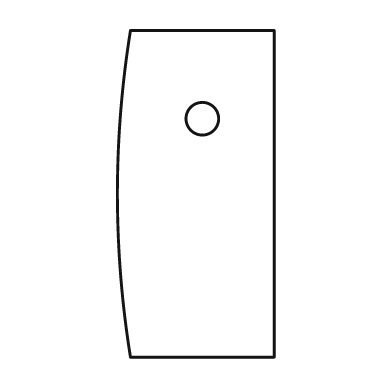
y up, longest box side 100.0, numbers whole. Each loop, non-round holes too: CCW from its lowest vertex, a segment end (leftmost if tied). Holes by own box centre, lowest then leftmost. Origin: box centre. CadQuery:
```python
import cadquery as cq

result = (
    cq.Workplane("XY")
    .moveTo(-20.0, -50.0)
    .lineTo(24.0, -50.0)
    .lineTo(24.0, 50.0)
    .lineTo(-20.0, 50.0)
    .threePointArc((-24.0, 0.0), (-20.0, -50.0))
    .close()
    .moveTo(2.0, 23.0)
    .circle(5.0)
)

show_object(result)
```